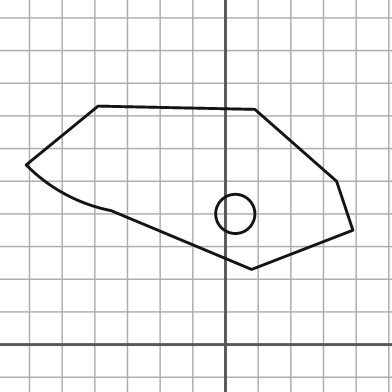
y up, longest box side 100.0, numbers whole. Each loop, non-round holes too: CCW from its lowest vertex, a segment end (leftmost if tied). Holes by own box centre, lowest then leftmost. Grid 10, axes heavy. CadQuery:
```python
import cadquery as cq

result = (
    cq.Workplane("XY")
    .moveTo(8.0, 23.0)
    .lineTo(39.0, 35.0)
    .lineTo(34.0, 50.0)
    .lineTo(9.0, 72.0)
    .lineTo(-39.0, 73.0)
    .lineTo(-61.0, 55.0)
    .threePointArc((-49.0, 46.0), (-35.0, 41.0))
    .close()
    .moveTo(3.0, 40.0)
    .circle(6.0)
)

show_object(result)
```